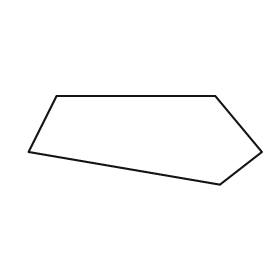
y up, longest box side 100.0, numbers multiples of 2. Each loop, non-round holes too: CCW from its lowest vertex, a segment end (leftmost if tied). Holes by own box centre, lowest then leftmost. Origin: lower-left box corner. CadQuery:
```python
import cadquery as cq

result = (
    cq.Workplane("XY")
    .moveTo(82.0, 0.0)
    .lineTo(100.0, 14.0)
    .lineTo(80.0, 38.0)
    .lineTo(12.0, 38.0)
    .lineTo(0.0, 14.0)
    .close()
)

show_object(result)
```